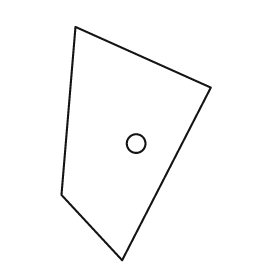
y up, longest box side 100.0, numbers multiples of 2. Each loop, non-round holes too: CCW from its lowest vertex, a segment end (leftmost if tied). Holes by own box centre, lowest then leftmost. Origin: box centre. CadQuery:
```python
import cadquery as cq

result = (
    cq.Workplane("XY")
    .moveTo(-6.0, -50.0)
    .lineTo(32.0, 24.0)
    .lineTo(-26.0, 50.0)
    .lineTo(-32.0, -22.0)
    .close()
    .moveTo(0.0, 0.0)
    .circle(4.0)
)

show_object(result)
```